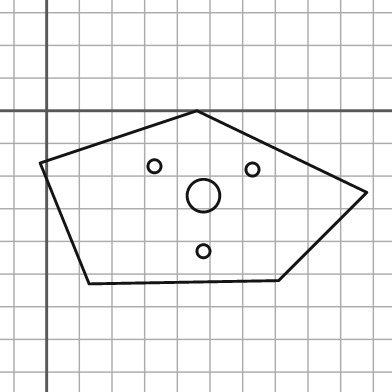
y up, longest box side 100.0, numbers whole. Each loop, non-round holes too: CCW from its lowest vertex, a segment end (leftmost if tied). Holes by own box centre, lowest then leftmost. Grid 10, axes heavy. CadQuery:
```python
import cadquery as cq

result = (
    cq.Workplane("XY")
    .moveTo(13.0, -53.0)
    .lineTo(71.0, -52.0)
    .lineTo(98.0, -25.0)
    .lineTo(46.0, 0.0)
    .lineTo(-2.0, -16.0)
    .close()
    .moveTo(48.0, -43.0)
    .circle(2.0)
    .moveTo(48.0, -26.0)
    .circle(5.0)
    .moveTo(63.0, -18.0)
    .circle(2.0)
    .moveTo(33.0, -17.0)
    .circle(2.0)
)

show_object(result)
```